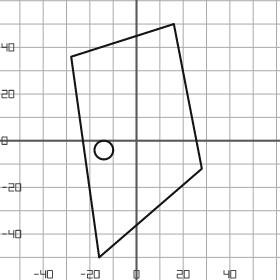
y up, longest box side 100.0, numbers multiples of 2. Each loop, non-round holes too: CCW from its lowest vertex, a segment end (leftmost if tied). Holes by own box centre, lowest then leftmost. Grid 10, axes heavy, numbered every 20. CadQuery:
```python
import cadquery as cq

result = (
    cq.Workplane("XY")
    .moveTo(-16.0, -50.0)
    .lineTo(28.0, -12.0)
    .lineTo(16.0, 50.0)
    .lineTo(-28.0, 36.0)
    .close()
    .moveTo(-14.0, -4.0)
    .circle(4.0)
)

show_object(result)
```